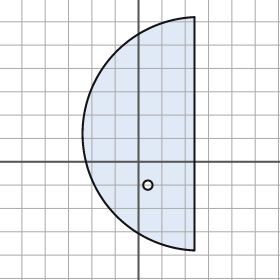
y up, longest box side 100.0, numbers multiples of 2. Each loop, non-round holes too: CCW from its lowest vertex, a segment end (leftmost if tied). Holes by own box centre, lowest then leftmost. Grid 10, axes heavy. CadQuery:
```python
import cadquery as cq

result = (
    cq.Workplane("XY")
    .moveTo(24.0, -38.0)
    .lineTo(24.0, 62.0)
    .threePointArc((-24.0, 12.0), (24.0, -38.0))
    .close()
    .moveTo(4.0, -10.0)
    .circle(2.0)
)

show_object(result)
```